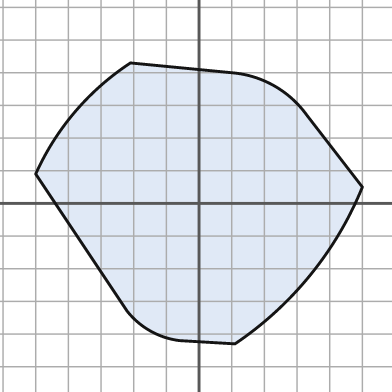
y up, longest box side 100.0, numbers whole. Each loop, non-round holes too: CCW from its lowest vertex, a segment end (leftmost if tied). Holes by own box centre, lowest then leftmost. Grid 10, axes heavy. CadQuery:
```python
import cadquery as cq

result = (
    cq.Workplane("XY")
    .moveTo(11.0, -43.0)
    .threePointArc((34.0, -22.0), (50.0, 5.0))
    .lineTo(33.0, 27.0)
    .threePointArc((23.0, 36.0), (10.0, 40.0))
    .lineTo(-21.0, 43.0)
    .threePointArc((-38.0, 28.0), (-50.0, 9.0))
    .lineTo(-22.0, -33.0)
    .threePointArc((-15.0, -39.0), (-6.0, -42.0))
    .close()
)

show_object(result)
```